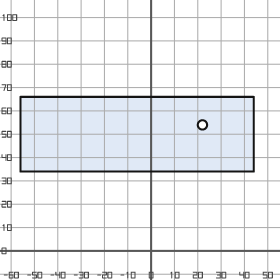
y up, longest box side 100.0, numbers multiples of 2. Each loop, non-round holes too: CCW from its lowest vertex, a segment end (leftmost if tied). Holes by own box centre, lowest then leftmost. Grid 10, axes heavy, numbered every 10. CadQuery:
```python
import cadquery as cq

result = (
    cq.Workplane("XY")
    .moveTo(-56.0, 34.0)
    .lineTo(44.0, 34.0)
    .lineTo(44.0, 66.0)
    .lineTo(-56.0, 66.0)
    .close()
    .moveTo(22.0, 54.0)
    .circle(2.0)
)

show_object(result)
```